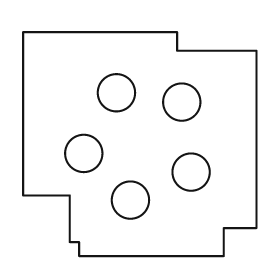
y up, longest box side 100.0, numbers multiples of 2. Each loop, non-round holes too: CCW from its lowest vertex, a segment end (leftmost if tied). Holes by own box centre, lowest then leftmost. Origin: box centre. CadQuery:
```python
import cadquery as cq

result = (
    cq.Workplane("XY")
    .moveTo(-26.0, -48.0)
    .lineTo(36.0, -48.0)
    .lineTo(36.0, -36.0)
    .lineTo(50.0, -36.0)
    .lineTo(50.0, 40.0)
    .lineTo(16.0, 40.0)
    .lineTo(16.0, 48.0)
    .lineTo(-50.0, 48.0)
    .lineTo(-50.0, -22.0)
    .lineTo(-30.0, -22.0)
    .lineTo(-30.0, -42.0)
    .lineTo(-26.0, -42.0)
    .close()
    .moveTo(-4.0, -24.0)
    .circle(8.0)
    .moveTo(22.0, -12.0)
    .circle(8.0)
    .moveTo(-24.0, -4.0)
    .circle(8.0)
    .moveTo(18.0, 18.0)
    .circle(8.0)
    .moveTo(-10.0, 22.0)
    .circle(8.0)
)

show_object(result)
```